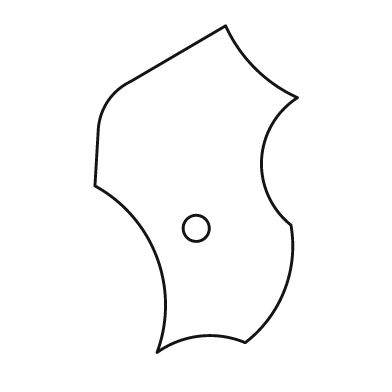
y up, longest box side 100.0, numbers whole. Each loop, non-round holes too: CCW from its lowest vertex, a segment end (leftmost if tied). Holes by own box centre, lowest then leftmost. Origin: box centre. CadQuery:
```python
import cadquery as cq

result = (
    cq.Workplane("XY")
    .moveTo(-12.0, -50.0)
    .threePointArc((1.0, -45.0), (15.0, -47.0))
    .threePointArc((27.0, -31.0), (29.0, -11.0))
    .threePointArc((20.0, 9.0), (31.0, 28.0))
    .threePointArc((18.0, 37.0), (9.0, 50.0))
    .lineTo(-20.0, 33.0)
    .threePointArc((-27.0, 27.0), (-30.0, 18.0))
    .lineTo(-31.0, 1.0)
    .threePointArc((-12.0, -21.0), (-12.0, -50.0))
    .close()
    .moveTo(0.0, -12.0)
    .circle(4.0)
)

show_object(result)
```